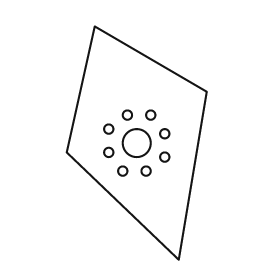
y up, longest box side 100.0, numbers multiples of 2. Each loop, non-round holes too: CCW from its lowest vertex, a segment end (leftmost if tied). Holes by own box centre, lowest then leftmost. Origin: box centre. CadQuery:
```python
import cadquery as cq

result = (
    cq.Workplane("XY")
    .moveTo(18.0, -50.0)
    .lineTo(30.0, 22.0)
    .lineTo(-18.0, 50.0)
    .lineTo(-30.0, -4.0)
    .close()
    .moveTo(-6.0, -12.0)
    .circle(2.0)
    .moveTo(4.0, -12.0)
    .circle(2.0)
    .moveTo(12.0, -6.0)
    .circle(2.0)
    .moveTo(-12.0, -4.0)
    .circle(2.0)
    .moveTo(0.0, 0.0)
    .circle(6.0)
    .moveTo(12.0, 4.0)
    .circle(2.0)
    .moveTo(-12.0, 6.0)
    .circle(2.0)
    .moveTo(-4.0, 12.0)
    .circle(2.0)
    .moveTo(6.0, 12.0)
    .circle(2.0)
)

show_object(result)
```